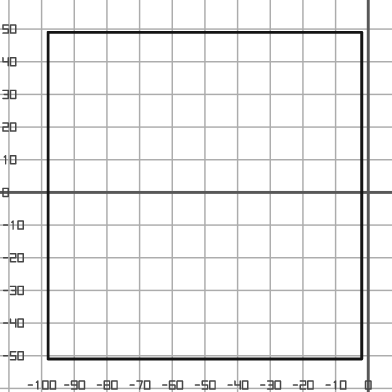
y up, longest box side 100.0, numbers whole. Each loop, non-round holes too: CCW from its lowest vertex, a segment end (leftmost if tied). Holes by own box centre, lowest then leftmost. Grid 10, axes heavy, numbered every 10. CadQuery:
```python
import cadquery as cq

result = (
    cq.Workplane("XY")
    .moveTo(-98.0, -51.0)
    .lineTo(-2.0, -51.0)
    .lineTo(-2.0, 49.0)
    .lineTo(-98.0, 49.0)
    .close()
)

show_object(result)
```